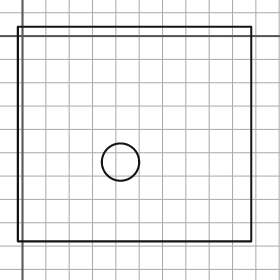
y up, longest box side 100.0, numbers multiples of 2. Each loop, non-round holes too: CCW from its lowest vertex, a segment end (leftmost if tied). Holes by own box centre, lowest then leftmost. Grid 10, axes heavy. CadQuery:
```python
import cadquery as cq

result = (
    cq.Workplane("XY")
    .moveTo(-2.0, -88.0)
    .lineTo(98.0, -88.0)
    .lineTo(98.0, 4.0)
    .lineTo(-2.0, 4.0)
    .close()
    .moveTo(42.0, -54.0)
    .circle(8.0)
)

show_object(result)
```